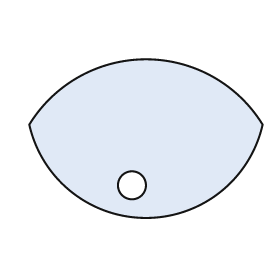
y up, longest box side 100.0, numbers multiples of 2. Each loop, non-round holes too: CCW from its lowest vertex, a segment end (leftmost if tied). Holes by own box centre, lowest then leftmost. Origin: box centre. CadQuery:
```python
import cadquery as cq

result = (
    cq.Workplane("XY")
    .moveTo(-50.0, 6.0)
    .threePointArc((0.0, -34.0), (50.0, 6.0))
    .threePointArc((0.0, 34.0), (-50.0, 6.0))
    .close()
    .moveTo(-6.0, -20.0)
    .circle(6.0)
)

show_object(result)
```